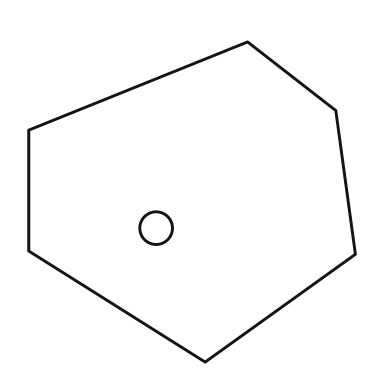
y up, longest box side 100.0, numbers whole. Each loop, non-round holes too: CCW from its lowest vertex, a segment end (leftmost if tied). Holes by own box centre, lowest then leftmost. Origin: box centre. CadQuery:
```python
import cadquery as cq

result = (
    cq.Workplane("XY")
    .moveTo(4.0, -49.0)
    .lineTo(50.0, -16.0)
    .lineTo(44.0, 28.0)
    .lineTo(17.0, 49.0)
    .lineTo(-50.0, 22.0)
    .lineTo(-50.0, -15.0)
    .close()
    .moveTo(-11.0, -8.0)
    .circle(5.0)
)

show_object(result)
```